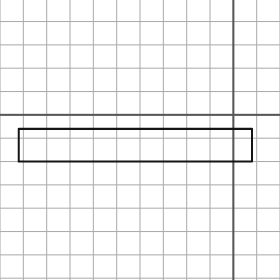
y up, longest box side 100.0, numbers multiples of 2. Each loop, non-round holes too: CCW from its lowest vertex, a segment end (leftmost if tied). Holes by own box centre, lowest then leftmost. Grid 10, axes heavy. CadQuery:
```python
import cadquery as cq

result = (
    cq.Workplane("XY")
    .moveTo(-92.0, -20.0)
    .lineTo(8.0, -20.0)
    .lineTo(8.0, -6.0)
    .lineTo(-92.0, -6.0)
    .close()
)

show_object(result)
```